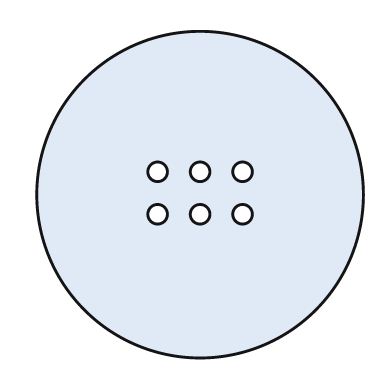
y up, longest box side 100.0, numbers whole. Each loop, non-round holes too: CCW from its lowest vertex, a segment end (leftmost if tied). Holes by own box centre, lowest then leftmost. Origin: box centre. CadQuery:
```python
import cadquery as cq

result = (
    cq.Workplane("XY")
    .moveTo(0.0, 0.0)
    .circle(50.0)
    .moveTo(-13.0, -6.0)
    .circle(3.0)
    .moveTo(0.0, -6.0)
    .circle(3.0)
    .moveTo(13.0, -6.0)
    .circle(3.0)
    .moveTo(-13.0, 7.0)
    .circle(3.0)
    .moveTo(0.0, 7.0)
    .circle(3.0)
    .moveTo(13.0, 7.0)
    .circle(3.0)
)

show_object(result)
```